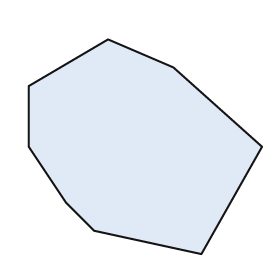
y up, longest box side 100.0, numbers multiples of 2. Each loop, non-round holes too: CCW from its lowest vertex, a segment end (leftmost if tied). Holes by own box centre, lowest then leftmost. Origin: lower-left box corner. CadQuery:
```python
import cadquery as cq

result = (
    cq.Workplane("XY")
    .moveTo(74.0, 0.0)
    .lineTo(100.0, 46.0)
    .lineTo(62.0, 80.0)
    .lineTo(34.0, 92.0)
    .lineTo(0.0, 72.0)
    .lineTo(0.0, 46.0)
    .lineTo(16.0, 22.0)
    .lineTo(28.0, 10.0)
    .close()
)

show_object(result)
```